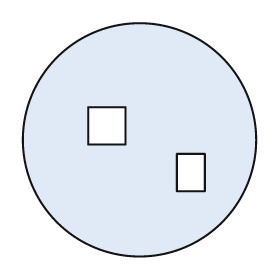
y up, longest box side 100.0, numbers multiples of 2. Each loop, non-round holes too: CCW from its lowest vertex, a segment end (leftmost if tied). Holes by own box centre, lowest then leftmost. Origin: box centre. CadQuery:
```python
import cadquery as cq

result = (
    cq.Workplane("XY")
    .moveTo(0.0, 0.0)
    .circle(50.0)
    .moveTo(16.0, -22.0)
    .lineTo(28.0, -22.0)
    .lineTo(28.0, -6.0)
    .lineTo(16.0, -6.0)
    .close()
    .moveTo(-22.0, -2.0)
    .lineTo(-6.0, -2.0)
    .lineTo(-6.0, 14.0)
    .lineTo(-22.0, 14.0)
    .close()
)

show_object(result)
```